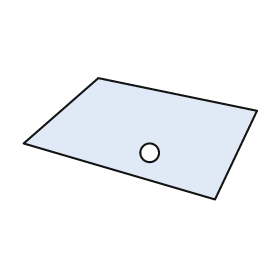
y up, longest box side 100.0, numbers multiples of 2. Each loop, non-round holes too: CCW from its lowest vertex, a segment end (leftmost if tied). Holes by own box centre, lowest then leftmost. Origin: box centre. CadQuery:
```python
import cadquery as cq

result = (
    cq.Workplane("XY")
    .moveTo(32.0, -26.0)
    .lineTo(50.0, 12.0)
    .lineTo(-18.0, 26.0)
    .lineTo(-50.0, -2.0)
    .close()
    .moveTo(4.0, -6.0)
    .circle(4.0)
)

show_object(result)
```